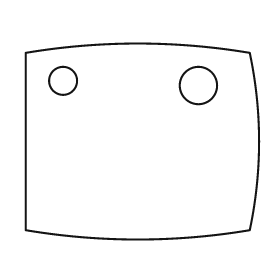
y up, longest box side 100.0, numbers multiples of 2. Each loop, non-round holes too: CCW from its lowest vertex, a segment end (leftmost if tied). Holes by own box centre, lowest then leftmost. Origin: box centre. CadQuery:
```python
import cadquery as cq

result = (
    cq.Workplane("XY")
    .moveTo(-50.0, -38.0)
    .threePointArc((-2.0, -42.0), (46.0, -38.0))
    .threePointArc((50.0, 0.0), (46.0, 38.0))
    .threePointArc((-2.0, 42.0), (-50.0, 38.0))
    .close()
    .moveTo(24.0, 24.0)
    .circle(8.0)
    .moveTo(-34.0, 26.0)
    .circle(6.0)
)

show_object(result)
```